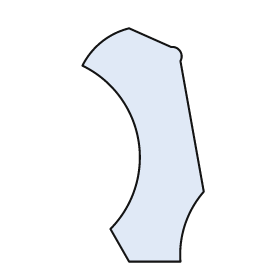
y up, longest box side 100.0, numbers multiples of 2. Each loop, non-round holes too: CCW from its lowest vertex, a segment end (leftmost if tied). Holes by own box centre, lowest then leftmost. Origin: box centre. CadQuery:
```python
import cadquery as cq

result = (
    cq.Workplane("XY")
    .moveTo(-6.0, -50.0)
    .lineTo(16.0, -50.0)
    .threePointArc((18.0, -34.0), (26.0, -20.0))
    .lineTo(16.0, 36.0)
    .threePointArc((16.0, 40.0), (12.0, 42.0))
    .lineTo(-6.0, 50.0)
    .threePointArc((-18.0, 44.0), (-26.0, 34.0))
    .threePointArc((-2.0, 2.0), (-14.0, -36.0))
    .close()
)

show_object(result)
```